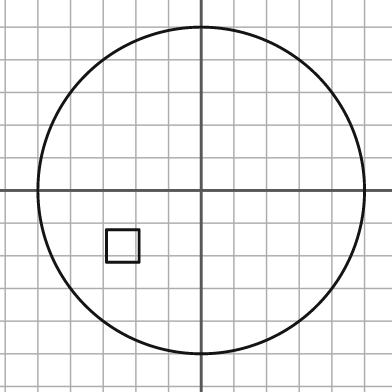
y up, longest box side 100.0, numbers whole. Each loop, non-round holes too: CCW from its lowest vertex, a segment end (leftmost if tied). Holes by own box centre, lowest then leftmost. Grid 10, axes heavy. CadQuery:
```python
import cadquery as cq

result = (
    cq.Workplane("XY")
    .moveTo(0.0, 0.0)
    .circle(50.0)
    .moveTo(-29.0, -22.0)
    .lineTo(-19.0, -22.0)
    .lineTo(-19.0, -12.0)
    .lineTo(-29.0, -12.0)
    .close()
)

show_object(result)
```